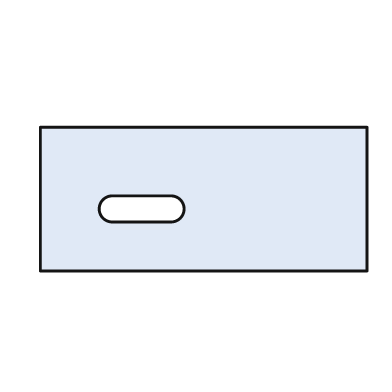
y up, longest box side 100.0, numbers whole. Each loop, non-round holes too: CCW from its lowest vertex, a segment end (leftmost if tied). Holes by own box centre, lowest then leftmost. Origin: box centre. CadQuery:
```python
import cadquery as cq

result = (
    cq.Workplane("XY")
    .moveTo(-50.0, -22.0)
    .lineTo(50.0, -22.0)
    .lineTo(50.0, 22.0)
    .lineTo(-50.0, 22.0)
    .close()
    .moveTo(-28.0, -7.0)
    .lineTo(-10.0, -7.0)
    .threePointArc((-6.0, -3.0), (-10.0, 1.0))
    .lineTo(-28.0, 1.0)
    .threePointArc((-32.0, -3.0), (-28.0, -7.0))
    .close()
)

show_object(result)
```